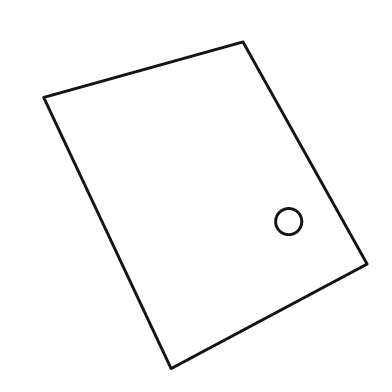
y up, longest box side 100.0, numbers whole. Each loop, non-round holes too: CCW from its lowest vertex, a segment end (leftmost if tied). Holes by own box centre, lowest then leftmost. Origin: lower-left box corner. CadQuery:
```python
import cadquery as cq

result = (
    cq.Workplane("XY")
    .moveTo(39.0, 0.0)
    .lineTo(99.0, 32.0)
    .lineTo(61.0, 100.0)
    .lineTo(0.0, 83.0)
    .close()
    .moveTo(75.0, 45.0)
    .circle(4.0)
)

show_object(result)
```